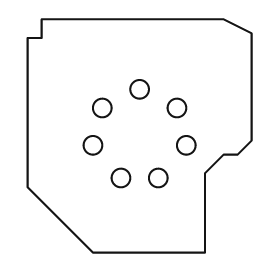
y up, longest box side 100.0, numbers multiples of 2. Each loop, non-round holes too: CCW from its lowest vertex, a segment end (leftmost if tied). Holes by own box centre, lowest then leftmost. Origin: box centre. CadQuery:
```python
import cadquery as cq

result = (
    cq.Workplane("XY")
    .moveTo(-20.0, -50.0)
    .lineTo(28.0, -50.0)
    .lineTo(28.0, -16.0)
    .lineTo(36.0, -8.0)
    .lineTo(42.0, -8.0)
    .lineTo(48.0, -2.0)
    .lineTo(48.0, 44.0)
    .lineTo(36.0, 50.0)
    .lineTo(-42.0, 50.0)
    .lineTo(-42.0, 42.0)
    .lineTo(-48.0, 42.0)
    .lineTo(-48.0, -22.0)
    .close()
    .moveTo(-8.0, -18.0)
    .circle(4.0)
    .moveTo(8.0, -18.0)
    .circle(4.0)
    .moveTo(-20.0, -4.0)
    .circle(4.0)
    .moveTo(20.0, -4.0)
    .circle(4.0)
    .moveTo(-16.0, 12.0)
    .circle(4.0)
    .moveTo(16.0, 12.0)
    .circle(4.0)
    .moveTo(0.0, 20.0)
    .circle(4.0)
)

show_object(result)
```